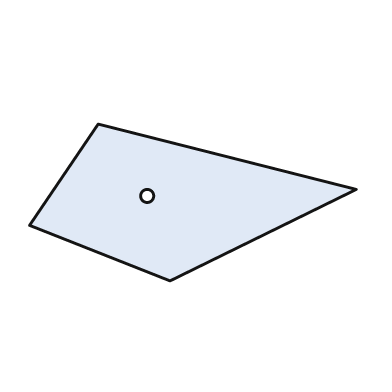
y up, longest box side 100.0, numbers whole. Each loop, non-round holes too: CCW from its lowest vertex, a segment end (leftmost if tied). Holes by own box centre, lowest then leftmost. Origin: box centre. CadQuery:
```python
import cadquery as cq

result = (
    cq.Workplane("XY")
    .moveTo(-7.0, -24.0)
    .lineTo(50.0, 4.0)
    .lineTo(-29.0, 24.0)
    .lineTo(-50.0, -7.0)
    .close()
    .moveTo(-14.0, 2.0)
    .circle(2.0)
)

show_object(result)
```